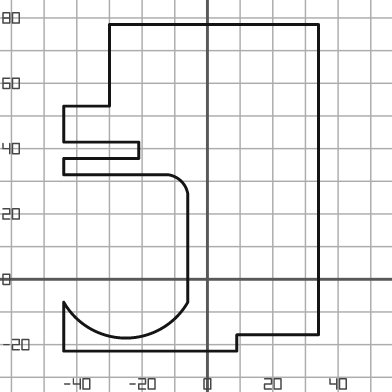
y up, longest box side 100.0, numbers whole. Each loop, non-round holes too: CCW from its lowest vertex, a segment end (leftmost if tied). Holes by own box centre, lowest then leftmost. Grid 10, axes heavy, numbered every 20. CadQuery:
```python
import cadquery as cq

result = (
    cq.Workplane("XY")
    .moveTo(-44.0, -22.0)
    .lineTo(9.0, -22.0)
    .lineTo(9.0, -17.0)
    .lineTo(34.0, -17.0)
    .lineTo(34.0, 78.0)
    .lineTo(-30.0, 78.0)
    .lineTo(-30.0, 53.0)
    .lineTo(-44.0, 53.0)
    .lineTo(-44.0, 42.0)
    .lineTo(-21.0, 42.0)
    .lineTo(-21.0, 37.0)
    .lineTo(-44.0, 37.0)
    .lineTo(-44.0, 32.0)
    .lineTo(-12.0, 32.0)
    .threePointArc((-8.0, 30.0), (-6.0, 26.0))
    .lineTo(-6.0, -7.0)
    .threePointArc((-25.0, -18.0), (-44.0, -7.0))
    .close()
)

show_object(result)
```